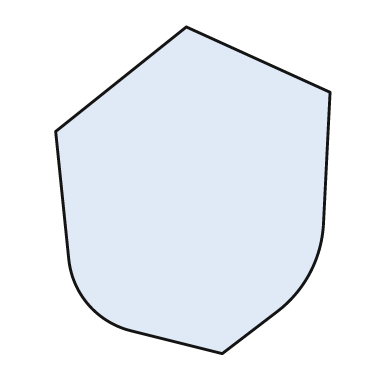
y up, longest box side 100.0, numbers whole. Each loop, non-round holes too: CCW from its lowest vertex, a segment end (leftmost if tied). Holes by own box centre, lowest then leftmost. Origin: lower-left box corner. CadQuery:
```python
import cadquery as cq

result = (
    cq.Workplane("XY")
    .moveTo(51.0, 0.0)
    .lineTo(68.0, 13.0)
    .threePointArc((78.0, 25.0), (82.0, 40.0))
    .lineTo(84.0, 80.0)
    .lineTo(40.0, 100.0)
    .lineTo(0.0, 68.0)
    .lineTo(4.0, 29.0)
    .threePointArc((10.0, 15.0), (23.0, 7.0))
    .close()
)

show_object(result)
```